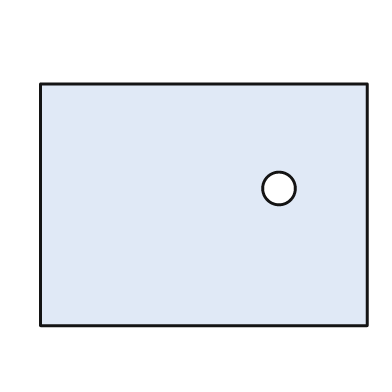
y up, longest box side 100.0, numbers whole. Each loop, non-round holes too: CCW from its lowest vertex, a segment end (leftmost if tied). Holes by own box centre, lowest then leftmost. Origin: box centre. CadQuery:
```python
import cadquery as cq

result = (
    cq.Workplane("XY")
    .moveTo(-50.0, -37.0)
    .lineTo(50.0, -37.0)
    .lineTo(50.0, 37.0)
    .lineTo(-50.0, 37.0)
    .close()
    .moveTo(23.0, 5.0)
    .circle(5.0)
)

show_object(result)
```